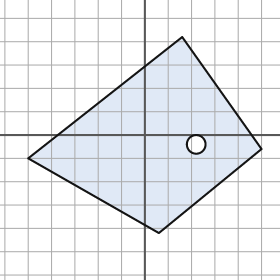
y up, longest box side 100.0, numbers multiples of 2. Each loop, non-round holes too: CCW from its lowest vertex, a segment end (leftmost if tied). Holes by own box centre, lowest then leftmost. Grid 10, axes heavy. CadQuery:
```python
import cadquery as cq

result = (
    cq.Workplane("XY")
    .moveTo(6.0, -42.0)
    .lineTo(50.0, -6.0)
    .lineTo(16.0, 42.0)
    .lineTo(-50.0, -10.0)
    .close()
    .moveTo(22.0, -4.0)
    .circle(4.0)
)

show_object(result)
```